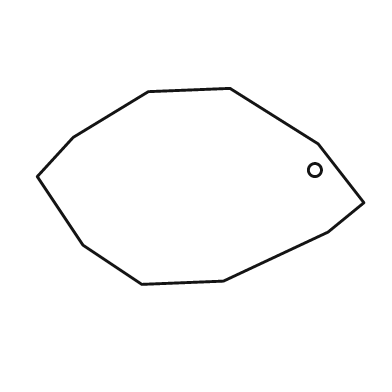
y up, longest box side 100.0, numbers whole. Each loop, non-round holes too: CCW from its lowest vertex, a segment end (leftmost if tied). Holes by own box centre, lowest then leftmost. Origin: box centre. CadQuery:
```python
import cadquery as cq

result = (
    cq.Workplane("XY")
    .moveTo(-18.0, -30.0)
    .lineTo(7.0, -29.0)
    .lineTo(39.0, -14.0)
    .lineTo(50.0, -5.0)
    .lineTo(36.0, 13.0)
    .lineTo(9.0, 30.0)
    .lineTo(-16.0, 29.0)
    .lineTo(-39.0, 15.0)
    .lineTo(-50.0, 3.0)
    .lineTo(-36.0, -18.0)
    .close()
    .moveTo(35.0, 5.0)
    .circle(2.0)
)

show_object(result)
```